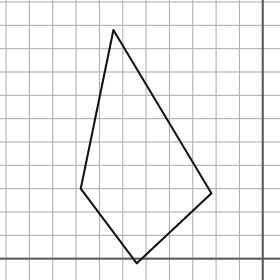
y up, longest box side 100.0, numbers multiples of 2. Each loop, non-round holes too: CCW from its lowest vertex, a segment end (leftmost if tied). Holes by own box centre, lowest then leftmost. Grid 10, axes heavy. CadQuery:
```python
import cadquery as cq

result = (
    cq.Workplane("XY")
    .moveTo(-54.0, -2.0)
    .lineTo(-22.0, 28.0)
    .lineTo(-64.0, 98.0)
    .lineTo(-78.0, 30.0)
    .close()
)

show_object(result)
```